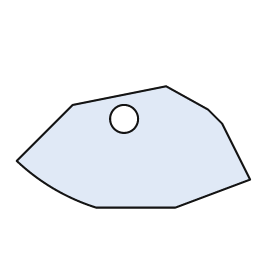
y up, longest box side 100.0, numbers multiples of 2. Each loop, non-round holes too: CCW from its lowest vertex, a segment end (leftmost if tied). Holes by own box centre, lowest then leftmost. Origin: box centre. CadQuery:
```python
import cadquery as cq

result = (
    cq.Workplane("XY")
    .moveTo(-16.0, -26.0)
    .lineTo(18.0, -26.0)
    .lineTo(50.0, -14.0)
    .lineTo(38.0, 10.0)
    .lineTo(32.0, 16.0)
    .lineTo(14.0, 26.0)
    .lineTo(-26.0, 18.0)
    .lineTo(-50.0, -6.0)
    .threePointArc((-34.0, -18.0), (-16.0, -26.0))
    .close()
    .moveTo(-4.0, 12.0)
    .circle(6.0)
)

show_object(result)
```